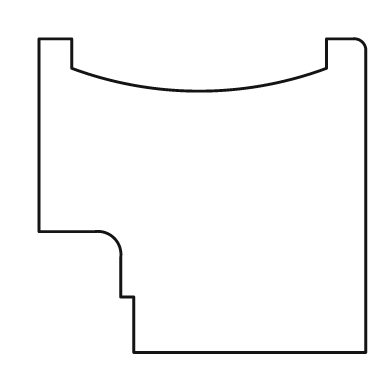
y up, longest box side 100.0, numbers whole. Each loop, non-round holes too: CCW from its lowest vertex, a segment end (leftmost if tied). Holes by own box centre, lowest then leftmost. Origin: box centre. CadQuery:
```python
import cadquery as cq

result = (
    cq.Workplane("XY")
    .moveTo(-21.0, -48.0)
    .lineTo(50.0, -48.0)
    .lineTo(50.0, 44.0)
    .threePointArc((49.0, 47.0), (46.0, 48.0))
    .lineTo(38.0, 48.0)
    .lineTo(38.0, 39.0)
    .threePointArc((-1.0, 32.0), (-40.0, 39.0))
    .lineTo(-40.0, 48.0)
    .lineTo(-50.0, 48.0)
    .lineTo(-50.0, -11.0)
    .lineTo(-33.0, -11.0)
    .threePointArc((-27.0, -13.0), (-25.0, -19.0))
    .lineTo(-25.0, -31.0)
    .lineTo(-21.0, -31.0)
    .close()
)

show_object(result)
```